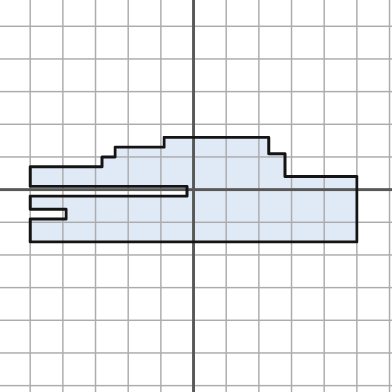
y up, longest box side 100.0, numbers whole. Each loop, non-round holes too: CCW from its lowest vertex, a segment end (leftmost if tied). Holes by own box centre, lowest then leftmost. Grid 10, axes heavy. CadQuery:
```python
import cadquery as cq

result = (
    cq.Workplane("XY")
    .moveTo(-50.0, -16.0)
    .lineTo(50.0, -16.0)
    .lineTo(50.0, 4.0)
    .lineTo(28.0, 4.0)
    .lineTo(28.0, 11.0)
    .lineTo(23.0, 11.0)
    .lineTo(23.0, 16.0)
    .lineTo(-9.0, 16.0)
    .lineTo(-9.0, 13.0)
    .lineTo(-24.0, 13.0)
    .lineTo(-24.0, 10.0)
    .lineTo(-28.0, 10.0)
    .lineTo(-28.0, 7.0)
    .lineTo(-50.0, 7.0)
    .lineTo(-50.0, 1.0)
    .lineTo(-2.0, 1.0)
    .lineTo(-2.0, -2.0)
    .lineTo(-50.0, -2.0)
    .lineTo(-50.0, -6.0)
    .lineTo(-39.0, -6.0)
    .lineTo(-39.0, -9.0)
    .lineTo(-50.0, -9.0)
    .close()
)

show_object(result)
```